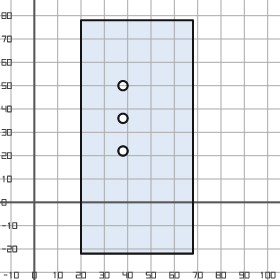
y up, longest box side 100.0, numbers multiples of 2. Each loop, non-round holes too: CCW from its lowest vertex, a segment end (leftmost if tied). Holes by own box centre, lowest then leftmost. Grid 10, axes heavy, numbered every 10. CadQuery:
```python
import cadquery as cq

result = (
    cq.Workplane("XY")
    .moveTo(20.0, -22.0)
    .lineTo(68.0, -22.0)
    .lineTo(68.0, 78.0)
    .lineTo(20.0, 78.0)
    .close()
    .moveTo(38.0, 22.0)
    .circle(2.0)
    .moveTo(38.0, 36.0)
    .circle(2.0)
    .moveTo(38.0, 50.0)
    .circle(2.0)
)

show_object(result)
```